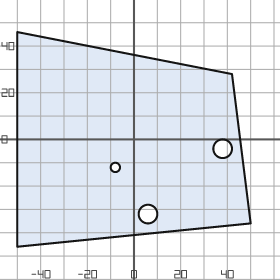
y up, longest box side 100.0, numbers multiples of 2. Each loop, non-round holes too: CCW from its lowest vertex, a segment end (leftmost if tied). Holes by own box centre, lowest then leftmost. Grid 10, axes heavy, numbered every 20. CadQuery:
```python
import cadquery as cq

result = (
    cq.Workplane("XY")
    .moveTo(-50.0, -46.0)
    .lineTo(50.0, -36.0)
    .lineTo(42.0, 28.0)
    .lineTo(-50.0, 46.0)
    .close()
    .moveTo(6.0, -32.0)
    .circle(4.0)
    .moveTo(-8.0, -12.0)
    .circle(2.0)
    .moveTo(38.0, -4.0)
    .circle(4.0)
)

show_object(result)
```